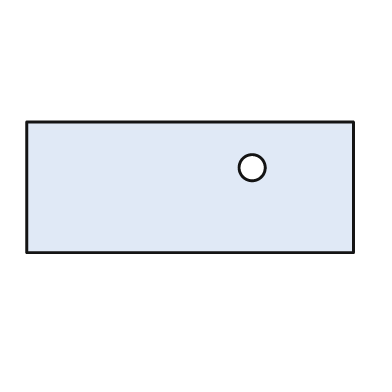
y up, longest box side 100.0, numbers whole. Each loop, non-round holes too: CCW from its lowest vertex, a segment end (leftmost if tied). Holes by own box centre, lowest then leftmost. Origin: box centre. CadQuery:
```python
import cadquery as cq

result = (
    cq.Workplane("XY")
    .moveTo(-50.0, -20.0)
    .lineTo(50.0, -20.0)
    .lineTo(50.0, 20.0)
    .lineTo(-50.0, 20.0)
    .close()
    .moveTo(19.0, 6.0)
    .circle(4.0)
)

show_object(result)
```